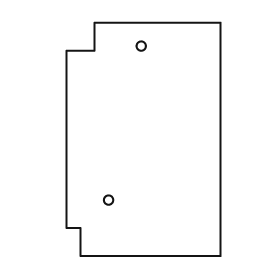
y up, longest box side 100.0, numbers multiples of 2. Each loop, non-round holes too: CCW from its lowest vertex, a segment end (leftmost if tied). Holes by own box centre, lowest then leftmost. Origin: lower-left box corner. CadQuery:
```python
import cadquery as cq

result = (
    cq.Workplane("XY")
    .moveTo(6.0, 0.0)
    .lineTo(66.0, 0.0)
    .lineTo(66.0, 100.0)
    .lineTo(12.0, 100.0)
    .lineTo(12.0, 88.0)
    .lineTo(0.0, 88.0)
    .lineTo(0.0, 12.0)
    .lineTo(6.0, 12.0)
    .close()
    .moveTo(18.0, 24.0)
    .circle(2.0)
    .moveTo(32.0, 90.0)
    .circle(2.0)
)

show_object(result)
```